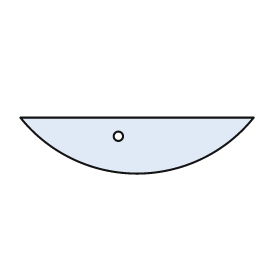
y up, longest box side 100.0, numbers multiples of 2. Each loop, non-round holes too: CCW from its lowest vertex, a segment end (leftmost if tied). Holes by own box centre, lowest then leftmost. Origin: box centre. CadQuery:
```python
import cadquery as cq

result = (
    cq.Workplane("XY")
    .moveTo(-50.0, 12.0)
    .threePointArc((0.0, -12.0), (50.0, 12.0))
    .close()
    .moveTo(-8.0, 4.0)
    .circle(2.0)
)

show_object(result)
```